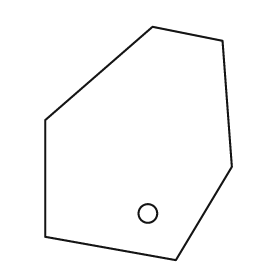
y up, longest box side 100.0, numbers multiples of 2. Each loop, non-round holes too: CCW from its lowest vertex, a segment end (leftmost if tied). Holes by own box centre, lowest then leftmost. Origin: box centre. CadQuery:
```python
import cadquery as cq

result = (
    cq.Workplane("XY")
    .moveTo(16.0, -50.0)
    .lineTo(40.0, -10.0)
    .lineTo(36.0, 44.0)
    .lineTo(6.0, 50.0)
    .lineTo(-40.0, 10.0)
    .lineTo(-40.0, -40.0)
    .close()
    .moveTo(4.0, -30.0)
    .circle(4.0)
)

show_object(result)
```